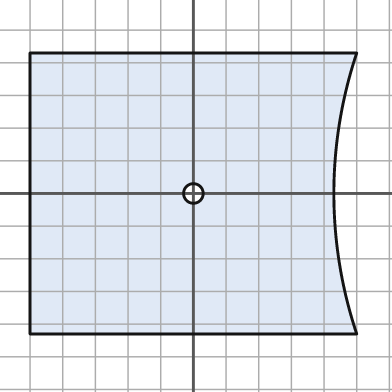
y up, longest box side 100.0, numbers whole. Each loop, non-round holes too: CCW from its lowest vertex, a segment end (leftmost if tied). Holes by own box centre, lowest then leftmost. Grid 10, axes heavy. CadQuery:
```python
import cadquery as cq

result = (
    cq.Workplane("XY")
    .moveTo(-50.0, -43.0)
    .lineTo(50.0, -43.0)
    .threePointArc((43.0, 0.0), (50.0, 43.0))
    .lineTo(-50.0, 43.0)
    .close()
    .moveTo(0.0, 0.0)
    .circle(3.0)
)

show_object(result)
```